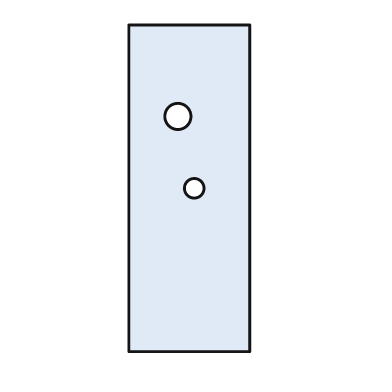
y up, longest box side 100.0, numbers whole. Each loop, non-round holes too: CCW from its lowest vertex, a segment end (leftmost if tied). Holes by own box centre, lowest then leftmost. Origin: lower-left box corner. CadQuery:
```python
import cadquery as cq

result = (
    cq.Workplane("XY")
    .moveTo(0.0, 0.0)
    .lineTo(37.0, 0.0)
    .lineTo(37.0, 100.0)
    .lineTo(0.0, 100.0)
    .close()
    .moveTo(20.0, 50.0)
    .circle(3.0)
    .moveTo(15.0, 72.0)
    .circle(4.0)
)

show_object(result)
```